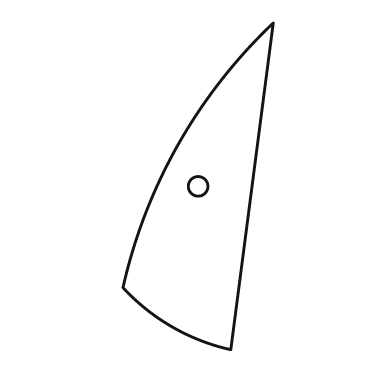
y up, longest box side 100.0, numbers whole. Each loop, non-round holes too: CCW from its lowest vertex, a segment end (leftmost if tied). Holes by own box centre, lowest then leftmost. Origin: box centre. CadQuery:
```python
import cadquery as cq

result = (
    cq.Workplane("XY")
    .moveTo(10.0, -50.0)
    .lineTo(23.0, 50.0)
    .threePointArc((-6.0, 13.0), (-23.0, -31.0))
    .threePointArc((-8.0, -43.0), (10.0, -50.0))
    .close()
    .moveTo(0.0, 0.0)
    .circle(3.0)
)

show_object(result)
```